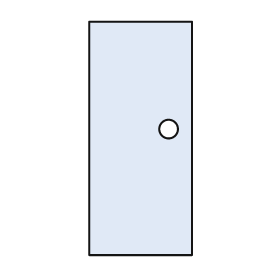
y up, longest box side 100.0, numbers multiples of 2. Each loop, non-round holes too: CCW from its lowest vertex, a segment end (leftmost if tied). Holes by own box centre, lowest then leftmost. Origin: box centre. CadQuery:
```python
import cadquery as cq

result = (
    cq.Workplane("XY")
    .moveTo(-22.0, -50.0)
    .lineTo(22.0, -50.0)
    .lineTo(22.0, 50.0)
    .lineTo(-22.0, 50.0)
    .close()
    .moveTo(12.0, 4.0)
    .circle(4.0)
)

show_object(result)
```